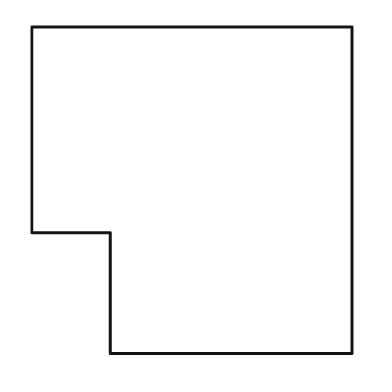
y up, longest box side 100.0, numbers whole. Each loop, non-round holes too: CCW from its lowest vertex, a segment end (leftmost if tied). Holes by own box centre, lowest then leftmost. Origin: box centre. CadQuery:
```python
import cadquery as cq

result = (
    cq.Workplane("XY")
    .moveTo(-25.0, -50.0)
    .lineTo(49.0, -50.0)
    .lineTo(49.0, 50.0)
    .lineTo(-49.0, 50.0)
    .lineTo(-49.0, -13.0)
    .lineTo(-25.0, -13.0)
    .close()
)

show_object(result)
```